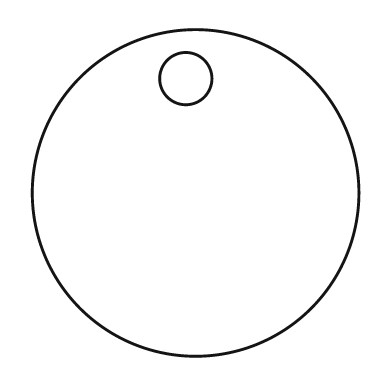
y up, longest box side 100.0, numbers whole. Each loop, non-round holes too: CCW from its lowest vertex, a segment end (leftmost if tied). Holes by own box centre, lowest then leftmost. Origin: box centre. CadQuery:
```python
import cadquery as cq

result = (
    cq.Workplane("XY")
    .moveTo(0.0, 0.0)
    .circle(50.0)
    .moveTo(-3.0, 35.0)
    .circle(8.0)
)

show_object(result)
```